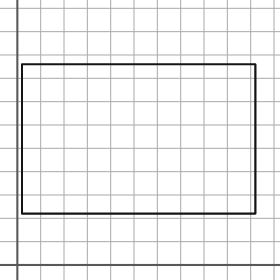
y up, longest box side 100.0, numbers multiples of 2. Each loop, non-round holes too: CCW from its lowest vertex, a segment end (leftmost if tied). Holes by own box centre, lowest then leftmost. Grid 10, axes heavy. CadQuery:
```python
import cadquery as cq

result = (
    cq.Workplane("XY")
    .moveTo(2.0, 22.0)
    .lineTo(102.0, 22.0)
    .lineTo(102.0, 86.0)
    .lineTo(2.0, 86.0)
    .close()
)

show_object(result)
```